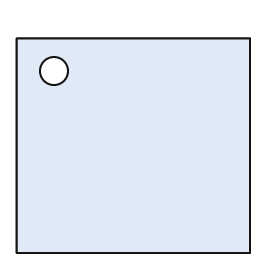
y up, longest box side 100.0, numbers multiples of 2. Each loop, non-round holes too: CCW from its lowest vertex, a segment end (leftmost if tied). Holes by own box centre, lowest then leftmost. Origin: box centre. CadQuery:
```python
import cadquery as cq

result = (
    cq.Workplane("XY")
    .moveTo(-50.0, -46.0)
    .lineTo(50.0, -46.0)
    .lineTo(50.0, 46.0)
    .lineTo(-50.0, 46.0)
    .close()
    .moveTo(-34.0, 32.0)
    .circle(6.0)
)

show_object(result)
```